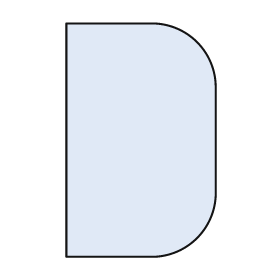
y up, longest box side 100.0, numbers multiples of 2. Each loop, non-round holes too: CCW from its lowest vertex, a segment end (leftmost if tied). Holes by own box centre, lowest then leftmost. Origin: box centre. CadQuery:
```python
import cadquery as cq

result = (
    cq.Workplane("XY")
    .moveTo(-32.0, -50.0)
    .lineTo(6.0, -50.0)
    .threePointArc((24.0, -42.0), (32.0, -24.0))
    .lineTo(32.0, 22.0)
    .threePointArc((24.0, 42.0), (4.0, 50.0))
    .lineTo(-32.0, 50.0)
    .close()
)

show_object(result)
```